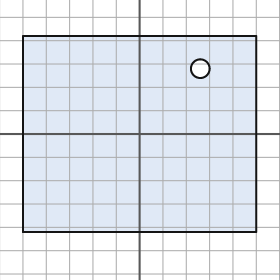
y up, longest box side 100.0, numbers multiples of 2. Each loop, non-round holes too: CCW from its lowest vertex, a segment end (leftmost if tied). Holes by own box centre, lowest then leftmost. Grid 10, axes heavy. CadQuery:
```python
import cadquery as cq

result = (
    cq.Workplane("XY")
    .moveTo(-50.0, -42.0)
    .lineTo(50.0, -42.0)
    .lineTo(50.0, 42.0)
    .lineTo(-50.0, 42.0)
    .close()
    .moveTo(26.0, 28.0)
    .circle(4.0)
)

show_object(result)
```